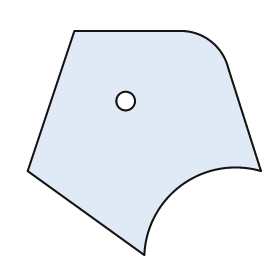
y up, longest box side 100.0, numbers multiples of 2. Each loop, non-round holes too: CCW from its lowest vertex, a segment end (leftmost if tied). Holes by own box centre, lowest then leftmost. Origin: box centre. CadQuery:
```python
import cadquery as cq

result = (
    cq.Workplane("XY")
    .moveTo(0.0, -48.0)
    .threePointArc((16.0, -18.0), (50.0, -12.0))
    .lineTo(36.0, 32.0)
    .threePointArc((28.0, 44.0), (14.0, 48.0))
    .lineTo(-30.0, 48.0)
    .lineTo(-50.0, -12.0)
    .close()
    .moveTo(-8.0, 18.0)
    .circle(4.0)
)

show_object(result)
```